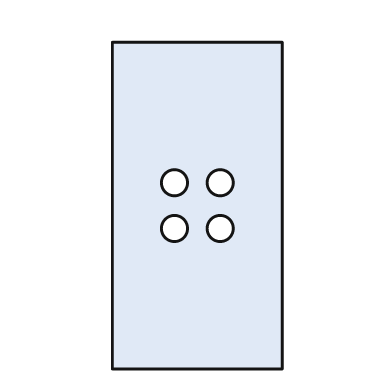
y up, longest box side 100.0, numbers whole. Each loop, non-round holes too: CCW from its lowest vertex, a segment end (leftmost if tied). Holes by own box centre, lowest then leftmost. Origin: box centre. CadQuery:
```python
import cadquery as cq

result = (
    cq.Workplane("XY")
    .moveTo(-26.0, -50.0)
    .lineTo(26.0, -50.0)
    .lineTo(26.0, 50.0)
    .lineTo(-26.0, 50.0)
    .close()
    .moveTo(-7.0, -7.0)
    .circle(4.0)
    .moveTo(7.0, -7.0)
    .circle(4.0)
    .moveTo(-7.0, 7.0)
    .circle(4.0)
    .moveTo(7.0, 7.0)
    .circle(4.0)
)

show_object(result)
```